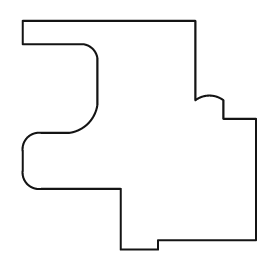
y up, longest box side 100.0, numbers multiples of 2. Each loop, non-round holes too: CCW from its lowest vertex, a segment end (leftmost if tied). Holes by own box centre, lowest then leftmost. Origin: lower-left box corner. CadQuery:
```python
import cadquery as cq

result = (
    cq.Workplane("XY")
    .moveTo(42.0, 0.0)
    .lineTo(58.0, 0.0)
    .lineTo(58.0, 4.0)
    .lineTo(100.0, 4.0)
    .lineTo(100.0, 56.0)
    .lineTo(86.0, 56.0)
    .lineTo(86.0, 64.0)
    .threePointArc((80.0, 66.0), (74.0, 64.0))
    .lineTo(74.0, 98.0)
    .lineTo(0.0, 98.0)
    .lineTo(0.0, 88.0)
    .lineTo(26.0, 88.0)
    .threePointArc((30.0, 86.0), (32.0, 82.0))
    .lineTo(32.0, 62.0)
    .threePointArc((28.0, 54.0), (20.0, 50.0))
    .lineTo(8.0, 50.0)
    .threePointArc((2.0, 48.0), (0.0, 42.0))
    .lineTo(0.0, 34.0)
    .threePointArc((2.0, 28.0), (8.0, 26.0))
    .lineTo(42.0, 26.0)
    .close()
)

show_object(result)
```